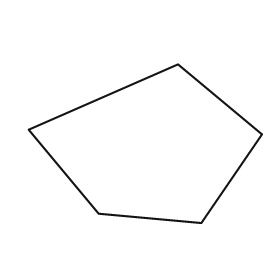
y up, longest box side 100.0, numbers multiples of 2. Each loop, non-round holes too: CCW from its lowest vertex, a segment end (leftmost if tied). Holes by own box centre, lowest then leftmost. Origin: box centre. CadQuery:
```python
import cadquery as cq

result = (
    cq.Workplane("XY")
    .moveTo(24.0, -34.0)
    .lineTo(50.0, 4.0)
    .lineTo(14.0, 34.0)
    .lineTo(-50.0, 6.0)
    .lineTo(-20.0, -30.0)
    .close()
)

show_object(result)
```